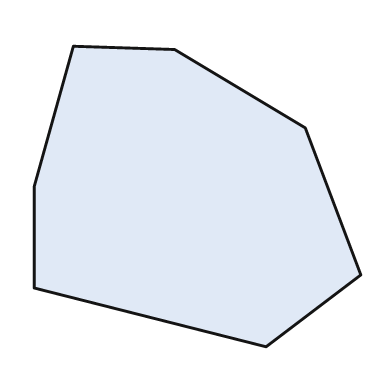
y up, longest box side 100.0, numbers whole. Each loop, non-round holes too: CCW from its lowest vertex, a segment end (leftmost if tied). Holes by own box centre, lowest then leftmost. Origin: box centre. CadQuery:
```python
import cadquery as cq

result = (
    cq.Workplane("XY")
    .moveTo(21.0, -46.0)
    .lineTo(50.0, -24.0)
    .lineTo(33.0, 21.0)
    .lineTo(-7.0, 45.0)
    .lineTo(-38.0, 46.0)
    .lineTo(-50.0, 3.0)
    .lineTo(-50.0, -28.0)
    .close()
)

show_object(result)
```